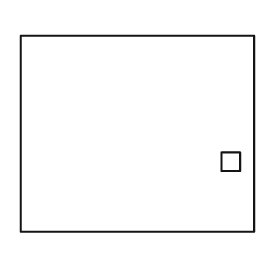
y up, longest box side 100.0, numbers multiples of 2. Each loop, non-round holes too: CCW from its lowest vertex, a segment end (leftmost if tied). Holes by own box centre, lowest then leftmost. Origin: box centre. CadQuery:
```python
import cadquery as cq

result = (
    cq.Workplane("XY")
    .moveTo(-50.0, -42.0)
    .lineTo(50.0, -42.0)
    .lineTo(50.0, 42.0)
    .lineTo(-50.0, 42.0)
    .close()
    .moveTo(36.0, -16.0)
    .lineTo(44.0, -16.0)
    .lineTo(44.0, -8.0)
    .lineTo(36.0, -8.0)
    .close()
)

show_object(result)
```